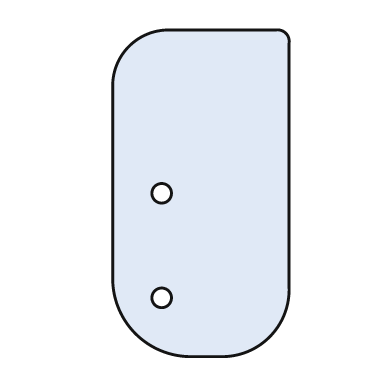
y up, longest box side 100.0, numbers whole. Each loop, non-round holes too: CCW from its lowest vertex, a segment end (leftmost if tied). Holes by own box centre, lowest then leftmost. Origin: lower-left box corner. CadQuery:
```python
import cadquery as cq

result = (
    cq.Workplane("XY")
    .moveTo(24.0, 0.0)
    .lineTo(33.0, 0.0)
    .threePointArc((48.0, 6.0), (54.0, 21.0))
    .lineTo(54.0, 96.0)
    .threePointArc((53.0, 99.0), (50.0, 100.0))
    .lineTo(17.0, 100.0)
    .threePointArc((5.0, 95.0), (0.0, 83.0))
    .lineTo(0.0, 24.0)
    .threePointArc((7.0, 7.0), (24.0, 0.0))
    .close()
    .moveTo(15.0, 18.0)
    .circle(3.0)
    .moveTo(15.0, 50.0)
    .circle(3.0)
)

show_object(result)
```